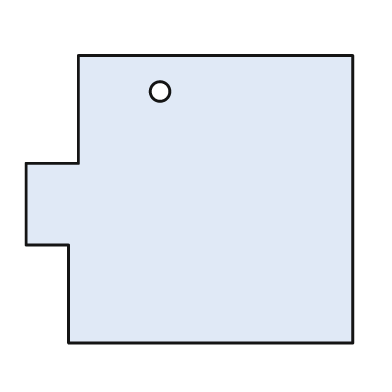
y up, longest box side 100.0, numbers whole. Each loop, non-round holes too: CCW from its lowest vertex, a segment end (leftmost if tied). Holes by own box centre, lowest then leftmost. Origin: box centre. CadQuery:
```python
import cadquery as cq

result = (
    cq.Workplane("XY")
    .moveTo(-37.0, -44.0)
    .lineTo(50.0, -44.0)
    .lineTo(50.0, 44.0)
    .lineTo(-34.0, 44.0)
    .lineTo(-34.0, 11.0)
    .lineTo(-50.0, 11.0)
    .lineTo(-50.0, -14.0)
    .lineTo(-37.0, -14.0)
    .close()
    .moveTo(-9.0, 33.0)
    .circle(3.0)
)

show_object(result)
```